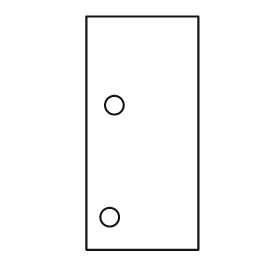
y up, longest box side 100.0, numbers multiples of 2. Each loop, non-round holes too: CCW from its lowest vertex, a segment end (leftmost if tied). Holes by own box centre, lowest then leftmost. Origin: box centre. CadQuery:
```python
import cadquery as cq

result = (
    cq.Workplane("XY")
    .moveTo(-24.0, -50.0)
    .lineTo(24.0, -50.0)
    .lineTo(24.0, 50.0)
    .lineTo(-24.0, 50.0)
    .close()
    .moveTo(-14.0, -36.0)
    .circle(4.0)
    .moveTo(-12.0, 12.0)
    .circle(4.0)
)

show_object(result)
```